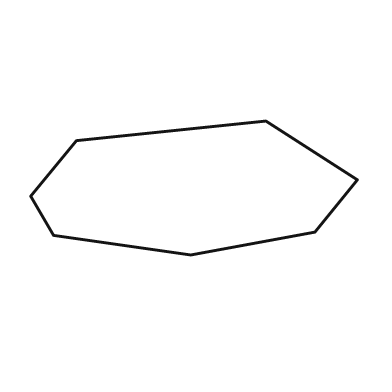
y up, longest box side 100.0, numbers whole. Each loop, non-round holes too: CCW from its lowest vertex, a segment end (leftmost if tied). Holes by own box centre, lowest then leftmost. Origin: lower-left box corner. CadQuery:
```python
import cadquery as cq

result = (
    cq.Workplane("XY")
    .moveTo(49.0, 0.0)
    .lineTo(87.0, 7.0)
    .lineTo(100.0, 23.0)
    .lineTo(72.0, 41.0)
    .lineTo(14.0, 35.0)
    .lineTo(0.0, 18.0)
    .lineTo(7.0, 6.0)
    .close()
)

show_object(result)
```